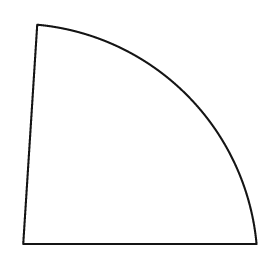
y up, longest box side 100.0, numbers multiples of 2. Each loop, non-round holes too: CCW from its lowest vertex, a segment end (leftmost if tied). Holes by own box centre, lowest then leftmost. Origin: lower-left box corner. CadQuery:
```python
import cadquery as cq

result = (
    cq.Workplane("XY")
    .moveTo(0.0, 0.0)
    .lineTo(100.0, 0.0)
    .threePointArc((70.0, 64.0), (6.0, 94.0))
    .close()
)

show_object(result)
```